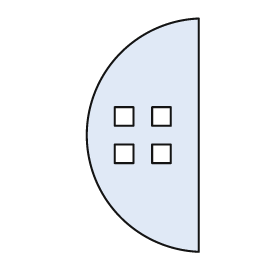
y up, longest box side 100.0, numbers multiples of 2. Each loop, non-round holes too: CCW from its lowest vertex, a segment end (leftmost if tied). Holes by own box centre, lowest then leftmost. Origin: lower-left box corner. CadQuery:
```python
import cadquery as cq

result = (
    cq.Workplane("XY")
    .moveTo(48.0, 0.0)
    .lineTo(48.0, 100.0)
    .threePointArc((0.0, 50.0), (48.0, 0.0))
    .close()
    .moveTo(12.0, 38.0)
    .lineTo(20.0, 38.0)
    .lineTo(20.0, 46.0)
    .lineTo(12.0, 46.0)
    .close()
    .moveTo(28.0, 38.0)
    .lineTo(36.0, 38.0)
    .lineTo(36.0, 46.0)
    .lineTo(28.0, 46.0)
    .close()
    .moveTo(12.0, 54.0)
    .lineTo(20.0, 54.0)
    .lineTo(20.0, 62.0)
    .lineTo(12.0, 62.0)
    .close()
    .moveTo(28.0, 54.0)
    .lineTo(36.0, 54.0)
    .lineTo(36.0, 62.0)
    .lineTo(28.0, 62.0)
    .close()
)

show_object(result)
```